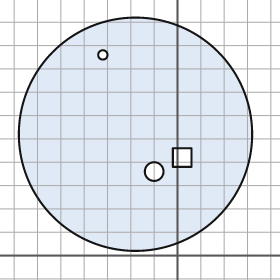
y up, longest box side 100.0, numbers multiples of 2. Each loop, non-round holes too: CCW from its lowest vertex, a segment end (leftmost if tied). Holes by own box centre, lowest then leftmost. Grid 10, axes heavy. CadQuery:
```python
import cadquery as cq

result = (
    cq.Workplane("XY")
    .moveTo(-18.0, 52.0)
    .circle(50.0)
    .moveTo(-10.0, 36.0)
    .circle(4.0)
    .moveTo(-2.0, 38.0)
    .lineTo(6.0, 38.0)
    .lineTo(6.0, 46.0)
    .lineTo(-2.0, 46.0)
    .close()
    .moveTo(-32.0, 86.0)
    .circle(2.0)
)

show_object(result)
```